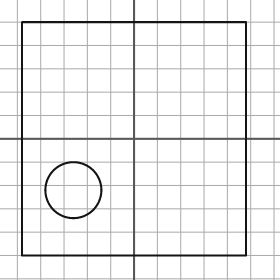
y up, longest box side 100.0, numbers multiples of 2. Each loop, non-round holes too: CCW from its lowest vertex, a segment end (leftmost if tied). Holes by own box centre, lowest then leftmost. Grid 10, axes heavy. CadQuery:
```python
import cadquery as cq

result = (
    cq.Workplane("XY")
    .moveTo(-48.0, -50.0)
    .lineTo(48.0, -50.0)
    .lineTo(48.0, 50.0)
    .lineTo(-48.0, 50.0)
    .close()
    .moveTo(-26.0, -22.0)
    .circle(12.0)
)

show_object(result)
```